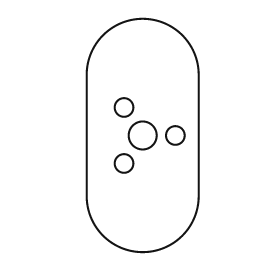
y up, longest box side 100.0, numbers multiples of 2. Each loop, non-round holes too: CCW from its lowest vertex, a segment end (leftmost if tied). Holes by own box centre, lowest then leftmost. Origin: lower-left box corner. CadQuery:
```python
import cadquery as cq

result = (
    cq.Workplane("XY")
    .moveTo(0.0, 24.0)
    .threePointArc((24.0, 0.0), (48.0, 24.0))
    .lineTo(48.0, 76.0)
    .threePointArc((24.0, 100.0), (0.0, 76.0))
    .close()
    .moveTo(16.0, 38.0)
    .circle(4.0)
    .moveTo(24.0, 50.0)
    .circle(6.0)
    .moveTo(38.0, 50.0)
    .circle(4.0)
    .moveTo(16.0, 62.0)
    .circle(4.0)
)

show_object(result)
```